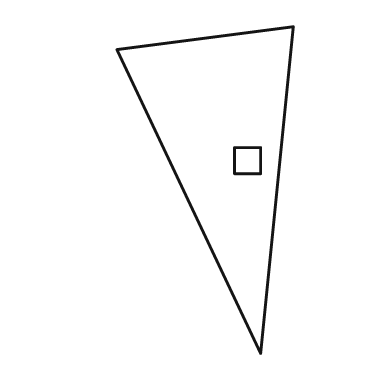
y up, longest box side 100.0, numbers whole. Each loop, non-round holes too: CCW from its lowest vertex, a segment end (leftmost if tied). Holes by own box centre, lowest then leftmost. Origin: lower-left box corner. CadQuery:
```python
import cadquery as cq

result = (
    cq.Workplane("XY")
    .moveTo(44.0, 0.0)
    .lineTo(54.0, 100.0)
    .lineTo(0.0, 93.0)
    .close()
    .moveTo(36.0, 55.0)
    .lineTo(44.0, 55.0)
    .lineTo(44.0, 63.0)
    .lineTo(36.0, 63.0)
    .close()
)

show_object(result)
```